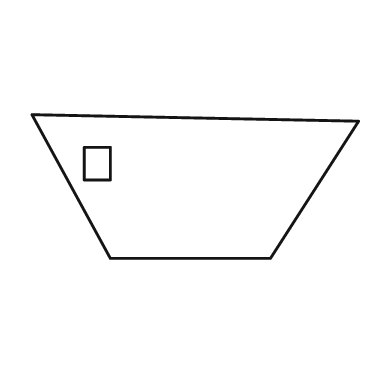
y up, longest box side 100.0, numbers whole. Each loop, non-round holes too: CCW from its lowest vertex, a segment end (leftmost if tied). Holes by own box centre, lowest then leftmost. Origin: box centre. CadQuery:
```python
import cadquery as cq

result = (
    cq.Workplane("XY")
    .moveTo(-26.0, -22.0)
    .lineTo(23.0, -22.0)
    .lineTo(50.0, 20.0)
    .lineTo(-50.0, 22.0)
    .close()
    .moveTo(-34.0, 2.0)
    .lineTo(-26.0, 2.0)
    .lineTo(-26.0, 12.0)
    .lineTo(-34.0, 12.0)
    .close()
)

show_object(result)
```